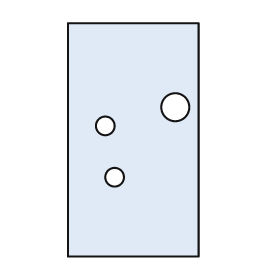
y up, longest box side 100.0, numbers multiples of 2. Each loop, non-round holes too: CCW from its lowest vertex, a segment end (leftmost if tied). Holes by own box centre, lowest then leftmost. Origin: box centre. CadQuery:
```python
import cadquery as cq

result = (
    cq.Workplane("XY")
    .moveTo(-28.0, -50.0)
    .lineTo(28.0, -50.0)
    .lineTo(28.0, 50.0)
    .lineTo(-28.0, 50.0)
    .close()
    .moveTo(-8.0, -16.0)
    .circle(4.0)
    .moveTo(-12.0, 6.0)
    .circle(4.0)
    .moveTo(18.0, 14.0)
    .circle(6.0)
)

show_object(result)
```